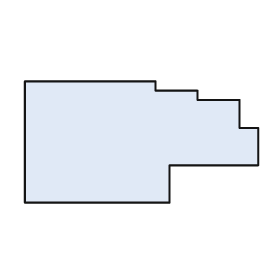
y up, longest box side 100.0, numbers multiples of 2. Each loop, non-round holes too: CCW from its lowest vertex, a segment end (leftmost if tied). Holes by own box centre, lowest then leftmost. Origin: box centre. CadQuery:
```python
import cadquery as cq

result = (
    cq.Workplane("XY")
    .moveTo(-50.0, -26.0)
    .lineTo(12.0, -26.0)
    .lineTo(12.0, -10.0)
    .lineTo(50.0, -10.0)
    .lineTo(50.0, 6.0)
    .lineTo(42.0, 6.0)
    .lineTo(42.0, 18.0)
    .lineTo(24.0, 18.0)
    .lineTo(24.0, 22.0)
    .lineTo(6.0, 22.0)
    .lineTo(6.0, 26.0)
    .lineTo(-50.0, 26.0)
    .close()
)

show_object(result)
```